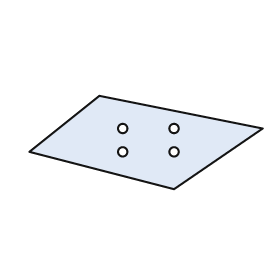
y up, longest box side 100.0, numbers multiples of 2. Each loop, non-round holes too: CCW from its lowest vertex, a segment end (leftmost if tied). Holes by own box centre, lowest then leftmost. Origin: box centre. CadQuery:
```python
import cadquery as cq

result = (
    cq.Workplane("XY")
    .moveTo(12.0, -20.0)
    .lineTo(50.0, 6.0)
    .lineTo(-20.0, 20.0)
    .lineTo(-50.0, -4.0)
    .close()
    .moveTo(-10.0, -4.0)
    .circle(2.0)
    .moveTo(12.0, -4.0)
    .circle(2.0)
    .moveTo(-10.0, 6.0)
    .circle(2.0)
    .moveTo(12.0, 6.0)
    .circle(2.0)
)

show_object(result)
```